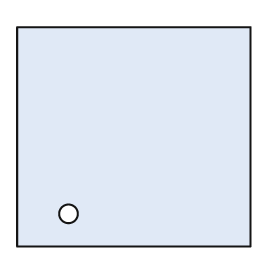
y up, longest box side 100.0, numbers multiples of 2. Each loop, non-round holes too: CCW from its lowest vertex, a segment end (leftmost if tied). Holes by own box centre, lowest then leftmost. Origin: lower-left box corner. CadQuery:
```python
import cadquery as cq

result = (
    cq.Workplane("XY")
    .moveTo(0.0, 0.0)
    .lineTo(100.0, 0.0)
    .lineTo(100.0, 94.0)
    .lineTo(0.0, 94.0)
    .close()
    .moveTo(22.0, 14.0)
    .circle(4.0)
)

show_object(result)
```